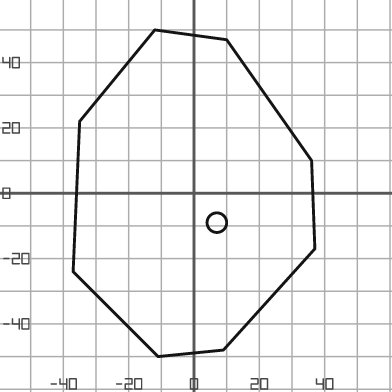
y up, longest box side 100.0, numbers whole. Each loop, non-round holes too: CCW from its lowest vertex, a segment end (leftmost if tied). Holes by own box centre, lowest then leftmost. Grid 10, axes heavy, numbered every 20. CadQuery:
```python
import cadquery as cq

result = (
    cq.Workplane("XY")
    .moveTo(-11.0, -50.0)
    .lineTo(9.0, -48.0)
    .lineTo(37.0, -17.0)
    .lineTo(36.0, 10.0)
    .lineTo(10.0, 47.0)
    .lineTo(-12.0, 50.0)
    .lineTo(-35.0, 22.0)
    .lineTo(-37.0, -24.0)
    .close()
    .moveTo(7.0, -9.0)
    .circle(3.0)
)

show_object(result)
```